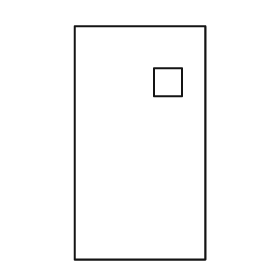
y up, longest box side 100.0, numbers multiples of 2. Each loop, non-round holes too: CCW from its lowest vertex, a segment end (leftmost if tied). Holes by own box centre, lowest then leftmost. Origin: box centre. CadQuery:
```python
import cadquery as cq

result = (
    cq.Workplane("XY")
    .moveTo(-28.0, -50.0)
    .lineTo(28.0, -50.0)
    .lineTo(28.0, 50.0)
    .lineTo(-28.0, 50.0)
    .close()
    .moveTo(6.0, 20.0)
    .lineTo(18.0, 20.0)
    .lineTo(18.0, 32.0)
    .lineTo(6.0, 32.0)
    .close()
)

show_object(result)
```